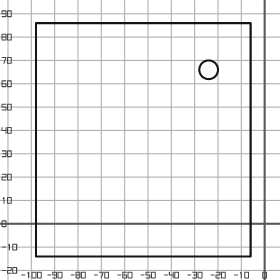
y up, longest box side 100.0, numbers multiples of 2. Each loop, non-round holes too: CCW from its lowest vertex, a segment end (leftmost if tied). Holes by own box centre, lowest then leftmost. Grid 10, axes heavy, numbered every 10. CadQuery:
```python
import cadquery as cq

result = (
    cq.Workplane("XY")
    .moveTo(-98.0, -14.0)
    .lineTo(-6.0, -14.0)
    .lineTo(-6.0, 86.0)
    .lineTo(-98.0, 86.0)
    .close()
    .moveTo(-24.0, 66.0)
    .circle(4.0)
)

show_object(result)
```